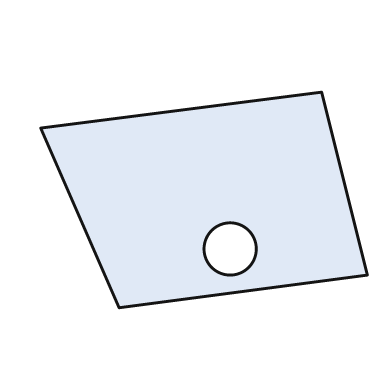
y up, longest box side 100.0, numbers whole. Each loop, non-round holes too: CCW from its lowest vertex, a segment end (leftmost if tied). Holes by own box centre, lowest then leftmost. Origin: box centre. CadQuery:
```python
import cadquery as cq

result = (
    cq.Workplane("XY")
    .moveTo(-26.0, -33.0)
    .lineTo(50.0, -23.0)
    .lineTo(36.0, 33.0)
    .lineTo(-50.0, 22.0)
    .close()
    .moveTo(8.0, -15.0)
    .circle(8.0)
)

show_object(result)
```